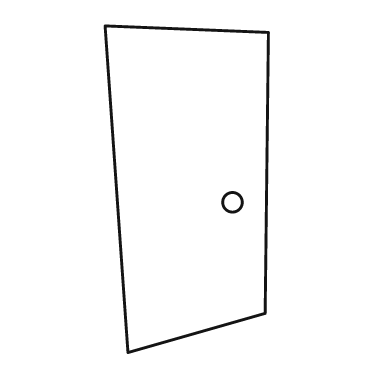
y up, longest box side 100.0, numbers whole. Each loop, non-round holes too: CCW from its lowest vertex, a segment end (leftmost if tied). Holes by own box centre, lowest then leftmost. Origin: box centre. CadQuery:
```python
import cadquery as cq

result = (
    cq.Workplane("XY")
    .moveTo(-18.0, -50.0)
    .lineTo(24.0, -38.0)
    .lineTo(25.0, 48.0)
    .lineTo(-25.0, 50.0)
    .close()
    .moveTo(14.0, -4.0)
    .circle(3.0)
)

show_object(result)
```